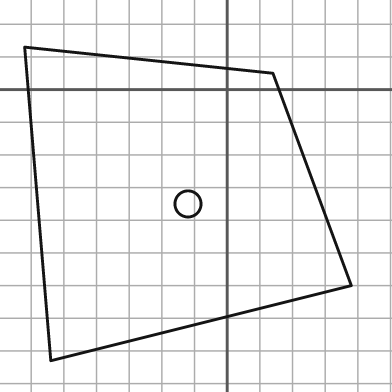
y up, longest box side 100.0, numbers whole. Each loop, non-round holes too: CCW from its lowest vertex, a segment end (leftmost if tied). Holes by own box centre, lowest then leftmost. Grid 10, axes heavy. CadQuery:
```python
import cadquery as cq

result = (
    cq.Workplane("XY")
    .moveTo(-54.0, -83.0)
    .lineTo(38.0, -60.0)
    .lineTo(14.0, 5.0)
    .lineTo(-62.0, 13.0)
    .close()
    .moveTo(-12.0, -35.0)
    .circle(4.0)
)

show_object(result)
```